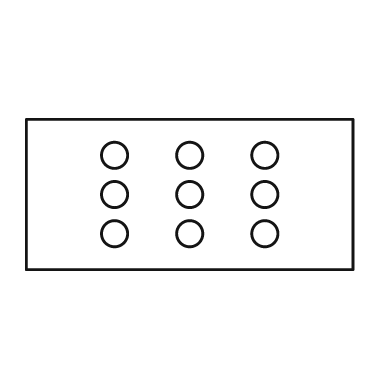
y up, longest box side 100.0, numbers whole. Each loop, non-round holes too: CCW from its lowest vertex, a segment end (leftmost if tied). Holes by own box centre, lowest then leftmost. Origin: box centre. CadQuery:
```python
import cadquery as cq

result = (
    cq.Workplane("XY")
    .moveTo(-50.0, -23.0)
    .lineTo(50.0, -23.0)
    .lineTo(50.0, 23.0)
    .lineTo(-50.0, 23.0)
    .close()
    .moveTo(-23.0, -12.0)
    .circle(4.0)
    .moveTo(0.0, -12.0)
    .circle(4.0)
    .moveTo(23.0, -12.0)
    .circle(4.0)
    .moveTo(-23.0, 0.0)
    .circle(4.0)
    .moveTo(0.0, 0.0)
    .circle(4.0)
    .moveTo(23.0, 0.0)
    .circle(4.0)
    .moveTo(-23.0, 12.0)
    .circle(4.0)
    .moveTo(0.0, 12.0)
    .circle(4.0)
    .moveTo(23.0, 12.0)
    .circle(4.0)
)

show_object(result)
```